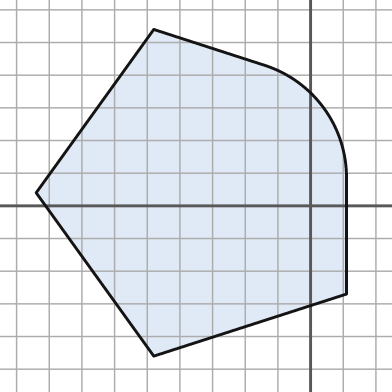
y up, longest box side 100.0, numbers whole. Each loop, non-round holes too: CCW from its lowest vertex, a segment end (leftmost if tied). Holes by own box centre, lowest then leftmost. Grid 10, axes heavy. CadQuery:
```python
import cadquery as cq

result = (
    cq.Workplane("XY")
    .moveTo(-48.0, -46.0)
    .lineTo(11.0, -27.0)
    .lineTo(11.0, 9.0)
    .threePointArc((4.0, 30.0), (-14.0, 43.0))
    .lineTo(-48.0, 54.0)
    .lineTo(-84.0, 4.0)
    .close()
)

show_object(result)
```